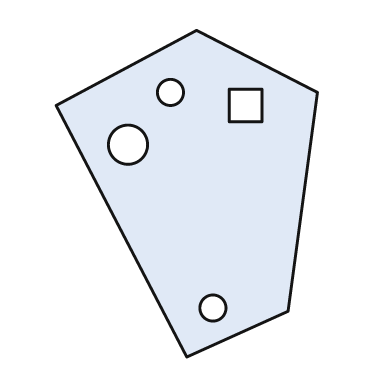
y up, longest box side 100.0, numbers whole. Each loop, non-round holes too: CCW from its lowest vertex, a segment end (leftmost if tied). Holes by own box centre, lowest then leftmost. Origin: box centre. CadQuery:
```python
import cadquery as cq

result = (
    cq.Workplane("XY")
    .moveTo(0.0, -50.0)
    .lineTo(31.0, -36.0)
    .lineTo(40.0, 31.0)
    .lineTo(3.0, 50.0)
    .lineTo(-40.0, 27.0)
    .close()
    .moveTo(8.0, -35.0)
    .circle(4.0)
    .moveTo(-18.0, 15.0)
    .circle(6.0)
    .moveTo(13.0, 22.0)
    .lineTo(23.0, 22.0)
    .lineTo(23.0, 32.0)
    .lineTo(13.0, 32.0)
    .close()
    .moveTo(-5.0, 31.0)
    .circle(4.0)
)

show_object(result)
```